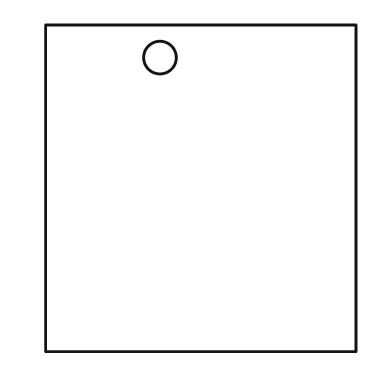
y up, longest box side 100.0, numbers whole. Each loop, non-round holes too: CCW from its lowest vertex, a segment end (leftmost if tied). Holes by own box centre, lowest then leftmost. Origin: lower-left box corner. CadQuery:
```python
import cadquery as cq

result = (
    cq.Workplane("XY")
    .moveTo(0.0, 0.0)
    .lineTo(95.0, 0.0)
    .lineTo(95.0, 100.0)
    .lineTo(0.0, 100.0)
    .close()
    .moveTo(35.0, 90.0)
    .circle(5.0)
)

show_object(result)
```